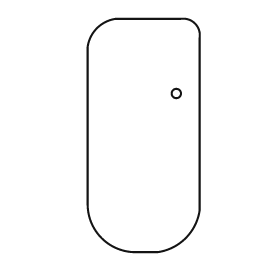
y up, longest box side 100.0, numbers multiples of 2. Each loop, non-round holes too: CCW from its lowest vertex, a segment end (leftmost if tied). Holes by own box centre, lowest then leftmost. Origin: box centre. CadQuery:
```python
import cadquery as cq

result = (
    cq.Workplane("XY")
    .moveTo(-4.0, -50.0)
    .lineTo(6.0, -50.0)
    .threePointArc((18.0, -44.0), (24.0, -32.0))
    .lineTo(24.0, 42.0)
    .threePointArc((22.0, 48.0), (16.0, 50.0))
    .lineTo(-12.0, 50.0)
    .threePointArc((-20.0, 46.0), (-24.0, 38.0))
    .lineTo(-24.0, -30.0)
    .threePointArc((-18.0, -44.0), (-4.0, -50.0))
    .close()
    .moveTo(14.0, 18.0)
    .circle(2.0)
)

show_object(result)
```